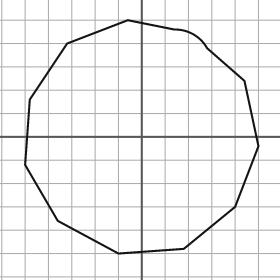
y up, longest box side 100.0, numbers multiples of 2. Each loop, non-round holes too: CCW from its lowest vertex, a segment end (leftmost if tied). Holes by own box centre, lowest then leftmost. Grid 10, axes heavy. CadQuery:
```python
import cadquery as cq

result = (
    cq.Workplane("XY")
    .moveTo(-10.0, -50.0)
    .lineTo(18.0, -48.0)
    .lineTo(40.0, -30.0)
    .lineTo(50.0, -4.0)
    .lineTo(44.0, 24.0)
    .lineTo(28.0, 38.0)
    .threePointArc((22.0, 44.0), (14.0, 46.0))
    .lineTo(-6.0, 50.0)
    .lineTo(-32.0, 40.0)
    .lineTo(-48.0, 16.0)
    .lineTo(-50.0, -12.0)
    .lineTo(-36.0, -36.0)
    .close()
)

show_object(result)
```